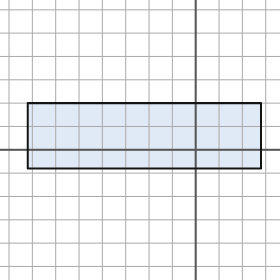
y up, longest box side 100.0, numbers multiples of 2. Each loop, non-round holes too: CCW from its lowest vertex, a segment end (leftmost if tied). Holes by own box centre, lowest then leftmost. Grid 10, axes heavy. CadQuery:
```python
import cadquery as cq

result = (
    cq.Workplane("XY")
    .moveTo(-72.0, -8.0)
    .lineTo(28.0, -8.0)
    .lineTo(28.0, 20.0)
    .lineTo(-72.0, 20.0)
    .close()
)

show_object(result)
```